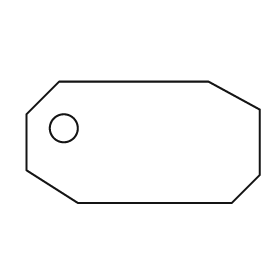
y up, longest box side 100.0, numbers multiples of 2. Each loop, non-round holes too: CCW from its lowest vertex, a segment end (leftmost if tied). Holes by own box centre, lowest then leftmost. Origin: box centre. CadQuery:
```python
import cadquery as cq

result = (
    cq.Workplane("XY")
    .moveTo(-28.0, -26.0)
    .lineTo(38.0, -26.0)
    .lineTo(50.0, -14.0)
    .lineTo(50.0, 14.0)
    .lineTo(28.0, 26.0)
    .lineTo(-36.0, 26.0)
    .lineTo(-50.0, 12.0)
    .lineTo(-50.0, -12.0)
    .close()
    .moveTo(-34.0, 6.0)
    .circle(6.0)
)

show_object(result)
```